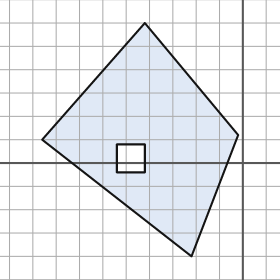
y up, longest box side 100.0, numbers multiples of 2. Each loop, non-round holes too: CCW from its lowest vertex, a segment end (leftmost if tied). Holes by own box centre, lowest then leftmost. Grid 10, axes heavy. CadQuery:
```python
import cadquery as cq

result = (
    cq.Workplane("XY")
    .moveTo(-22.0, -40.0)
    .lineTo(-2.0, 12.0)
    .lineTo(-42.0, 60.0)
    .lineTo(-86.0, 10.0)
    .close()
    .moveTo(-54.0, -4.0)
    .lineTo(-42.0, -4.0)
    .lineTo(-42.0, 8.0)
    .lineTo(-54.0, 8.0)
    .close()
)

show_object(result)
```